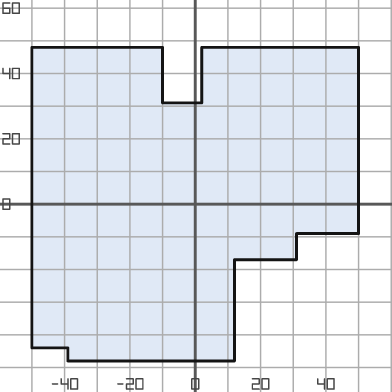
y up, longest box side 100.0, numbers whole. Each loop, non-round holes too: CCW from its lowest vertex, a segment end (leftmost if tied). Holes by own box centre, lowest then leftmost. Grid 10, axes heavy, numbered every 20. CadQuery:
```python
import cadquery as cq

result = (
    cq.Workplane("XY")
    .moveTo(-39.0, -48.0)
    .lineTo(12.0, -48.0)
    .lineTo(12.0, -17.0)
    .lineTo(31.0, -17.0)
    .lineTo(31.0, -9.0)
    .lineTo(50.0, -9.0)
    .lineTo(50.0, 48.0)
    .lineTo(2.0, 48.0)
    .lineTo(2.0, 31.0)
    .lineTo(-10.0, 31.0)
    .lineTo(-10.0, 48.0)
    .lineTo(-50.0, 48.0)
    .lineTo(-50.0, -44.0)
    .lineTo(-39.0, -44.0)
    .close()
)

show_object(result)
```